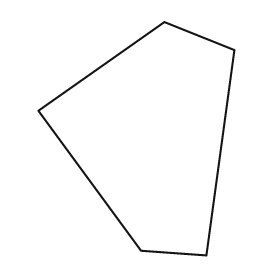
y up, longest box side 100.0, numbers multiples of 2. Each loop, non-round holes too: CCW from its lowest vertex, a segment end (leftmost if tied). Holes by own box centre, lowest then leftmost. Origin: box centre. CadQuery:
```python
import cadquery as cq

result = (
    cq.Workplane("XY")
    .moveTo(30.0, -50.0)
    .lineTo(42.0, 38.0)
    .lineTo(12.0, 50.0)
    .lineTo(-42.0, 12.0)
    .lineTo(2.0, -48.0)
    .close()
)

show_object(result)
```